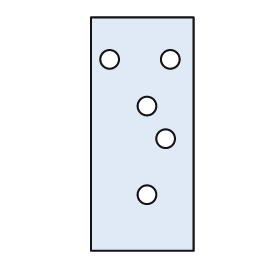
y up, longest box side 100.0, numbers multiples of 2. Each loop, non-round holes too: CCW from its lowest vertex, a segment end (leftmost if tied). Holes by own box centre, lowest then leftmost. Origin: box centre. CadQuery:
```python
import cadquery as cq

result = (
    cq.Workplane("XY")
    .moveTo(-22.0, -50.0)
    .lineTo(22.0, -50.0)
    .lineTo(22.0, 50.0)
    .lineTo(-22.0, 50.0)
    .close()
    .moveTo(2.0, -26.0)
    .circle(4.0)
    .moveTo(10.0, -2.0)
    .circle(4.0)
    .moveTo(2.0, 12.0)
    .circle(4.0)
    .moveTo(-14.0, 32.0)
    .circle(4.0)
    .moveTo(12.0, 32.0)
    .circle(4.0)
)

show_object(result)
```